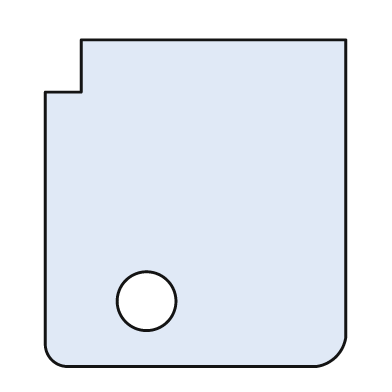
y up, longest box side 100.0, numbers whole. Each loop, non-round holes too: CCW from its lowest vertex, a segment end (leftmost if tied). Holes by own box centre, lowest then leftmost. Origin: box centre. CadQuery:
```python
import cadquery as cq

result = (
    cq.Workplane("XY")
    .moveTo(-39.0, -50.0)
    .lineTo(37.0, -50.0)
    .threePointArc((43.0, -47.0), (46.0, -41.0))
    .lineTo(46.0, 50.0)
    .lineTo(-35.0, 50.0)
    .lineTo(-35.0, 34.0)
    .lineTo(-46.0, 34.0)
    .lineTo(-46.0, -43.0)
    .threePointArc((-44.0, -48.0), (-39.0, -50.0))
    .close()
    .moveTo(-15.0, -30.0)
    .circle(9.0)
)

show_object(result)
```